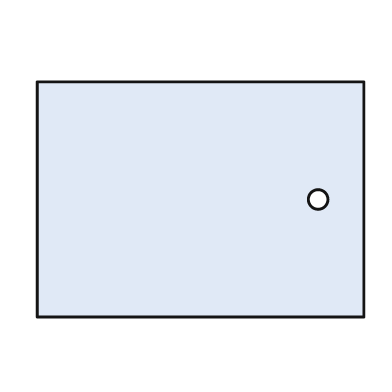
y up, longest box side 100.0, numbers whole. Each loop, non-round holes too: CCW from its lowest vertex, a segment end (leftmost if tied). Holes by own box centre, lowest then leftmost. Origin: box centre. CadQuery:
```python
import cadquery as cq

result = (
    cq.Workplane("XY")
    .moveTo(-50.0, -36.0)
    .lineTo(50.0, -36.0)
    .lineTo(50.0, 36.0)
    .lineTo(-50.0, 36.0)
    .close()
    .moveTo(36.0, 0.0)
    .circle(3.0)
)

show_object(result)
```